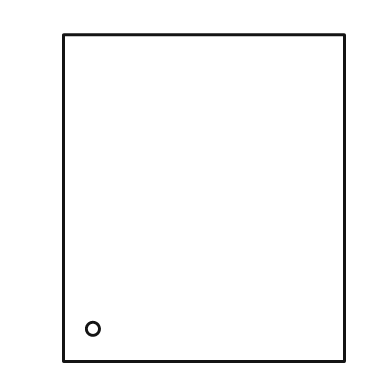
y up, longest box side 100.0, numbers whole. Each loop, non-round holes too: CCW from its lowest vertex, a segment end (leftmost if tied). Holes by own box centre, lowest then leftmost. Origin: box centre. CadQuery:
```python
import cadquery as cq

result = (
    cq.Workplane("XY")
    .moveTo(-43.0, -50.0)
    .lineTo(43.0, -50.0)
    .lineTo(43.0, 50.0)
    .lineTo(-43.0, 50.0)
    .close()
    .moveTo(-34.0, -40.0)
    .circle(2.0)
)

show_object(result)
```